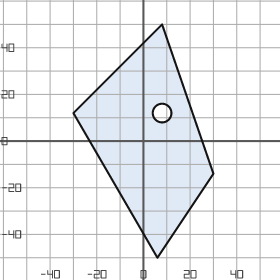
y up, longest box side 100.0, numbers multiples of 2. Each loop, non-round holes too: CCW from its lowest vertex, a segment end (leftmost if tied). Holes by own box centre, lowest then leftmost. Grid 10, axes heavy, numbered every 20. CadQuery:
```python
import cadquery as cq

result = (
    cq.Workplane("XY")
    .moveTo(6.0, -50.0)
    .lineTo(30.0, -14.0)
    .lineTo(8.0, 50.0)
    .lineTo(-30.0, 12.0)
    .close()
    .moveTo(8.0, 12.0)
    .circle(4.0)
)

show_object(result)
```